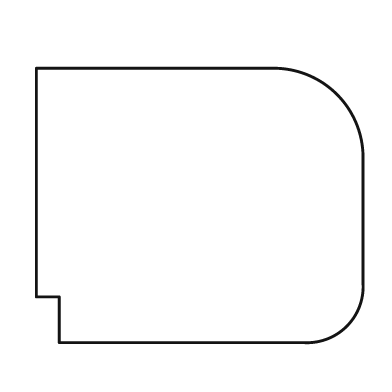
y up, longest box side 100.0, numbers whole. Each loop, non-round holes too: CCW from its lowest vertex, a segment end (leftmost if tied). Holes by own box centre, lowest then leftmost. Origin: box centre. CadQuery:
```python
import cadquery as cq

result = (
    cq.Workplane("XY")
    .moveTo(-43.0, -42.0)
    .lineTo(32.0, -42.0)
    .threePointArc((45.0, -37.0), (50.0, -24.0))
    .lineTo(50.0, 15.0)
    .threePointArc((42.0, 34.0), (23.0, 42.0))
    .lineTo(-50.0, 42.0)
    .lineTo(-50.0, -28.0)
    .lineTo(-43.0, -28.0)
    .close()
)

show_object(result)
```